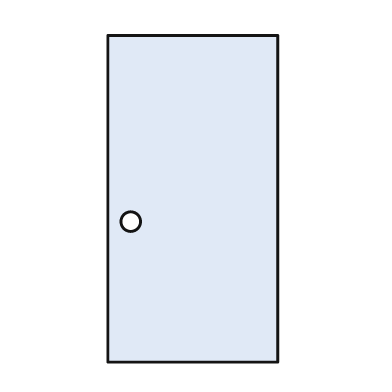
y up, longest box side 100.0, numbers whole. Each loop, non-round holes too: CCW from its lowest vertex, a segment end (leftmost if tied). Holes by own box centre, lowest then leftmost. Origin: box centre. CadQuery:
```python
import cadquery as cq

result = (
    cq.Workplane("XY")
    .moveTo(-26.0, -50.0)
    .lineTo(26.0, -50.0)
    .lineTo(26.0, 50.0)
    .lineTo(-26.0, 50.0)
    .close()
    .moveTo(-19.0, -7.0)
    .circle(3.0)
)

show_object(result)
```